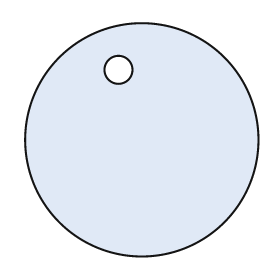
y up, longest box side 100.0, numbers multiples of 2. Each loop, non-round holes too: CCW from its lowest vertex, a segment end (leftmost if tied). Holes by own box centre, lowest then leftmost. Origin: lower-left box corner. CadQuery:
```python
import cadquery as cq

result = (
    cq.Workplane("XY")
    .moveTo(50.0, 50.0)
    .circle(50.0)
    .moveTo(40.0, 80.0)
    .circle(6.0)
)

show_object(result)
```